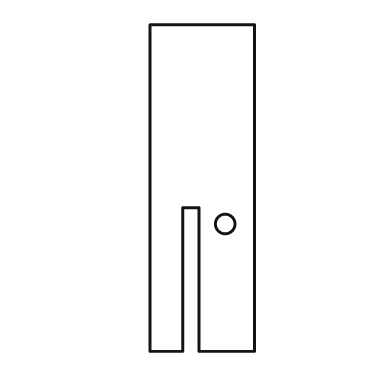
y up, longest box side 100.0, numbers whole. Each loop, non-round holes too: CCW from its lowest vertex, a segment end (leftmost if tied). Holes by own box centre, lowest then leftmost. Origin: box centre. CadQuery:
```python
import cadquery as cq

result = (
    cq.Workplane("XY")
    .moveTo(-16.0, -50.0)
    .lineTo(-6.0, -50.0)
    .lineTo(-6.0, -6.0)
    .lineTo(-1.0, -6.0)
    .lineTo(-1.0, -50.0)
    .lineTo(16.0, -50.0)
    .lineTo(16.0, 50.0)
    .lineTo(-16.0, 50.0)
    .close()
    .moveTo(7.0, -11.0)
    .circle(3.0)
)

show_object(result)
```